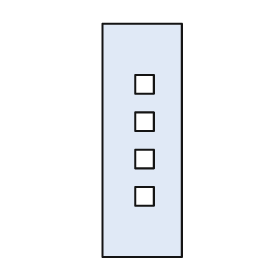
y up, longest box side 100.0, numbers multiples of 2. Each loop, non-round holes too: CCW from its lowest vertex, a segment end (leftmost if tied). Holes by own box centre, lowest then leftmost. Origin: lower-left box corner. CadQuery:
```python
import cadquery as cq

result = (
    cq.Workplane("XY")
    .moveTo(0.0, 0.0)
    .lineTo(34.0, 0.0)
    .lineTo(34.0, 100.0)
    .lineTo(0.0, 100.0)
    .close()
    .moveTo(14.0, 22.0)
    .lineTo(22.0, 22.0)
    .lineTo(22.0, 30.0)
    .lineTo(14.0, 30.0)
    .close()
    .moveTo(14.0, 38.0)
    .lineTo(22.0, 38.0)
    .lineTo(22.0, 46.0)
    .lineTo(14.0, 46.0)
    .close()
    .moveTo(14.0, 54.0)
    .lineTo(22.0, 54.0)
    .lineTo(22.0, 62.0)
    .lineTo(14.0, 62.0)
    .close()
    .moveTo(14.0, 70.0)
    .lineTo(22.0, 70.0)
    .lineTo(22.0, 78.0)
    .lineTo(14.0, 78.0)
    .close()
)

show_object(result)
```